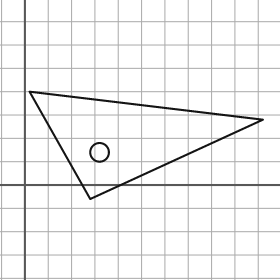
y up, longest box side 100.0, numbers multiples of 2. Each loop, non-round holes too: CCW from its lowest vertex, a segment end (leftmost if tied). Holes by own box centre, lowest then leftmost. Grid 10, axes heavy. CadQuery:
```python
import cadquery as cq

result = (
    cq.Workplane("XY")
    .moveTo(28.0, -6.0)
    .lineTo(102.0, 28.0)
    .lineTo(2.0, 40.0)
    .close()
    .moveTo(32.0, 14.0)
    .circle(4.0)
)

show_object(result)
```